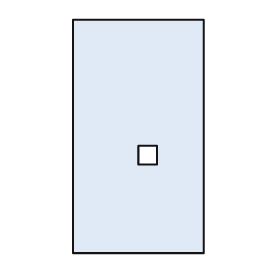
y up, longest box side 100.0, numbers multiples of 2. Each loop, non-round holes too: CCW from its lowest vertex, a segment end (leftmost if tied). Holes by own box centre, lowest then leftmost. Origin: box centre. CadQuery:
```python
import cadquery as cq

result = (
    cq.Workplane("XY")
    .moveTo(-28.0, -50.0)
    .lineTo(28.0, -50.0)
    .lineTo(28.0, 50.0)
    .lineTo(-28.0, 50.0)
    .close()
    .moveTo(0.0, -12.0)
    .lineTo(8.0, -12.0)
    .lineTo(8.0, -4.0)
    .lineTo(0.0, -4.0)
    .close()
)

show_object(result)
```